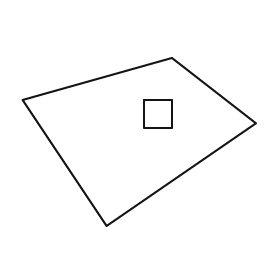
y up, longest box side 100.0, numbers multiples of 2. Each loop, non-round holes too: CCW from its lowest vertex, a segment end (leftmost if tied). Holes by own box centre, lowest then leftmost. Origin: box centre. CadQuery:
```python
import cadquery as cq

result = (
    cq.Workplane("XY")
    .moveTo(-14.0, -36.0)
    .lineTo(50.0, 8.0)
    .lineTo(14.0, 36.0)
    .lineTo(-50.0, 18.0)
    .close()
    .moveTo(2.0, 6.0)
    .lineTo(14.0, 6.0)
    .lineTo(14.0, 18.0)
    .lineTo(2.0, 18.0)
    .close()
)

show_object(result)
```